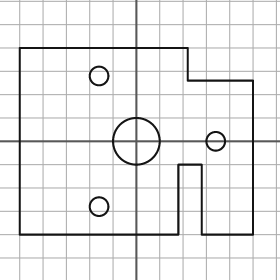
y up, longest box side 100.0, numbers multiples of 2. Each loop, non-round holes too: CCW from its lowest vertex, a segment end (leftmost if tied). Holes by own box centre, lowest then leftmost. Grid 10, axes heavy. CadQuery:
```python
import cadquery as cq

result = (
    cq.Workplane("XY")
    .moveTo(-50.0, -40.0)
    .lineTo(18.0, -40.0)
    .lineTo(18.0, -10.0)
    .lineTo(28.0, -10.0)
    .lineTo(28.0, -40.0)
    .lineTo(50.0, -40.0)
    .lineTo(50.0, 26.0)
    .lineTo(22.0, 26.0)
    .lineTo(22.0, 40.0)
    .lineTo(-50.0, 40.0)
    .close()
    .moveTo(-16.0, -28.0)
    .circle(4.0)
    .moveTo(0.0, 0.0)
    .circle(10.0)
    .moveTo(34.0, 0.0)
    .circle(4.0)
    .moveTo(-16.0, 28.0)
    .circle(4.0)
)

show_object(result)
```